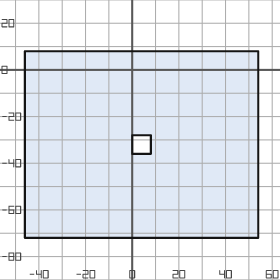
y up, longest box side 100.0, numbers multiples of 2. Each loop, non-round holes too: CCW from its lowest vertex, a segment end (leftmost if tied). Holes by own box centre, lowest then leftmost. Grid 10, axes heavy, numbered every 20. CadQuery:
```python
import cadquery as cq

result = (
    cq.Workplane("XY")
    .moveTo(-46.0, -72.0)
    .lineTo(54.0, -72.0)
    .lineTo(54.0, 8.0)
    .lineTo(-46.0, 8.0)
    .close()
    .moveTo(0.0, -36.0)
    .lineTo(8.0, -36.0)
    .lineTo(8.0, -28.0)
    .lineTo(0.0, -28.0)
    .close()
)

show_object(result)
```